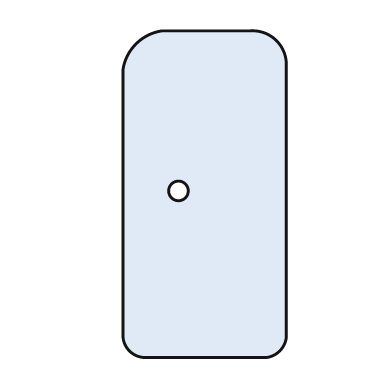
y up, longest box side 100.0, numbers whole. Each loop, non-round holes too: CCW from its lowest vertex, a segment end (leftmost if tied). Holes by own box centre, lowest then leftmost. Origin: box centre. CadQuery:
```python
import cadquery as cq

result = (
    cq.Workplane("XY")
    .moveTo(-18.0, -50.0)
    .lineTo(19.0, -50.0)
    .threePointArc((23.0, -48.0), (25.0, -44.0))
    .lineTo(25.0, 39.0)
    .threePointArc((22.0, 47.0), (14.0, 50.0))
    .lineTo(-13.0, 50.0)
    .threePointArc((-21.0, 46.0), (-25.0, 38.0))
    .lineTo(-25.0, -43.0)
    .threePointArc((-23.0, -48.0), (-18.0, -50.0))
    .close()
    .moveTo(-8.0, 1.0)
    .circle(3.0)
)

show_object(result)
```